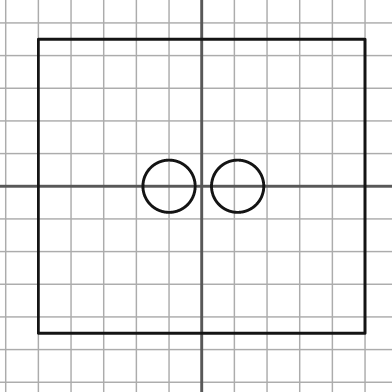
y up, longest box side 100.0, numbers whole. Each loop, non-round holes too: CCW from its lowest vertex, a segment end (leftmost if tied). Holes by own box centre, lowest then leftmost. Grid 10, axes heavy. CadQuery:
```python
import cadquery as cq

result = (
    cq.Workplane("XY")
    .moveTo(-50.0, -45.0)
    .lineTo(50.0, -45.0)
    .lineTo(50.0, 45.0)
    .lineTo(-50.0, 45.0)
    .close()
    .moveTo(-10.0, 0.0)
    .circle(8.0)
    .moveTo(11.0, 0.0)
    .circle(8.0)
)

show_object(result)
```